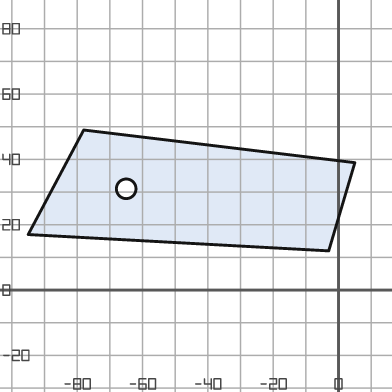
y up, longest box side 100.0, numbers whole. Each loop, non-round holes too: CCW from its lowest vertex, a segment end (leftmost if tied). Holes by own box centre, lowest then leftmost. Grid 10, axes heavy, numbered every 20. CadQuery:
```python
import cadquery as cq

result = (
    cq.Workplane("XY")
    .moveTo(-3.0, 12.0)
    .lineTo(5.0, 39.0)
    .lineTo(-78.0, 49.0)
    .lineTo(-95.0, 17.0)
    .close()
    .moveTo(-65.0, 31.0)
    .circle(3.0)
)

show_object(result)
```